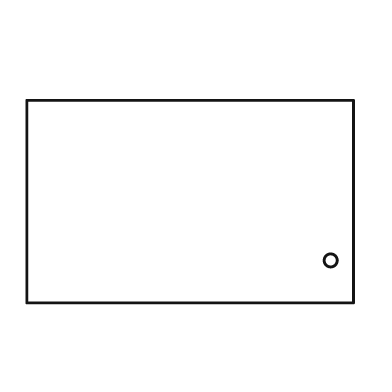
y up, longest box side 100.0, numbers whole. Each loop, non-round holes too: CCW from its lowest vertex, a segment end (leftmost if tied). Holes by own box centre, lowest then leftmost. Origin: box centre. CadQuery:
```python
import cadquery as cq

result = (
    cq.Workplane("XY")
    .moveTo(-50.0, -31.0)
    .lineTo(50.0, -31.0)
    .lineTo(50.0, 31.0)
    .lineTo(-50.0, 31.0)
    .close()
    .moveTo(43.0, -18.0)
    .circle(2.0)
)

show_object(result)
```